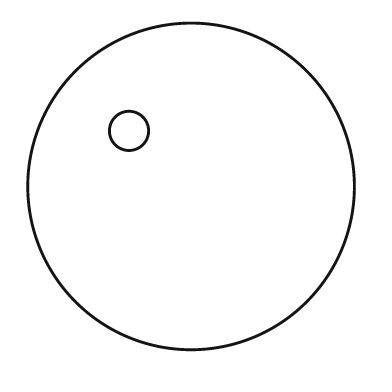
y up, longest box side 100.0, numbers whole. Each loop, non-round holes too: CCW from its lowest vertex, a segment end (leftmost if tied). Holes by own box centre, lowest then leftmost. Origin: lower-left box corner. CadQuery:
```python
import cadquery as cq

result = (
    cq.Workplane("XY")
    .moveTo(50.0, 50.0)
    .circle(50.0)
    .moveTo(31.0, 67.0)
    .circle(6.0)
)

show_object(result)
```